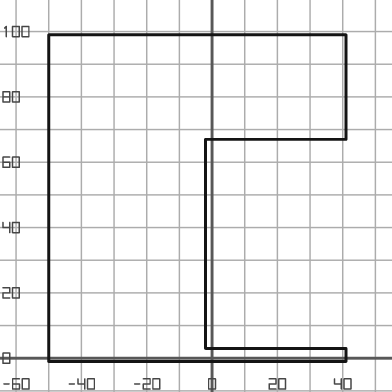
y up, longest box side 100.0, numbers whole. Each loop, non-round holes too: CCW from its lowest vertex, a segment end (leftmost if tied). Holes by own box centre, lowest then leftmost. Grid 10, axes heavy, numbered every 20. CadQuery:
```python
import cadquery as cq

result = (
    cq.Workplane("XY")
    .moveTo(-50.0, -1.0)
    .lineTo(41.0, -1.0)
    .lineTo(41.0, 3.0)
    .lineTo(-2.0, 3.0)
    .lineTo(-2.0, 67.0)
    .lineTo(41.0, 67.0)
    .lineTo(41.0, 99.0)
    .lineTo(-50.0, 99.0)
    .close()
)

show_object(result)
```